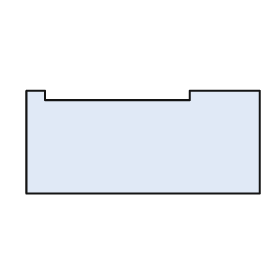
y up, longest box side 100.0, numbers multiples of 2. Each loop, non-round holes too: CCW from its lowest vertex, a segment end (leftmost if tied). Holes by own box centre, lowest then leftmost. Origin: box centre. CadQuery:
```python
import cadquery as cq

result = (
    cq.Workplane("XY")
    .moveTo(-50.0, -22.0)
    .lineTo(50.0, -22.0)
    .lineTo(50.0, 22.0)
    .lineTo(20.0, 22.0)
    .lineTo(20.0, 18.0)
    .lineTo(-42.0, 18.0)
    .lineTo(-42.0, 22.0)
    .lineTo(-50.0, 22.0)
    .close()
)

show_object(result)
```